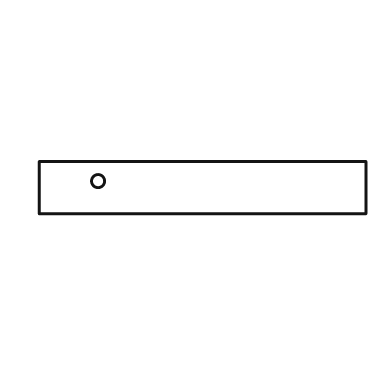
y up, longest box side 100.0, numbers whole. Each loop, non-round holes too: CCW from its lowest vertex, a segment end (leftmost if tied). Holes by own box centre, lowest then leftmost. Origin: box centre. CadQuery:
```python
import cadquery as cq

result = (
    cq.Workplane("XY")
    .moveTo(-50.0, -8.0)
    .lineTo(50.0, -8.0)
    .lineTo(50.0, 8.0)
    .lineTo(-50.0, 8.0)
    .close()
    .moveTo(-32.0, 2.0)
    .circle(2.0)
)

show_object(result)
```